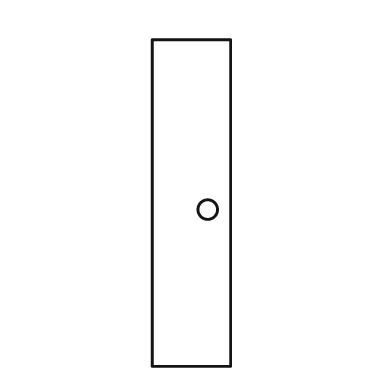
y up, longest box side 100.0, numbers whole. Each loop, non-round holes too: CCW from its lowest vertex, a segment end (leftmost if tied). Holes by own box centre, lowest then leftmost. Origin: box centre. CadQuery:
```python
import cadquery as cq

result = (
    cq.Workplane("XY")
    .moveTo(-12.0, -50.0)
    .lineTo(12.0, -50.0)
    .lineTo(12.0, 50.0)
    .lineTo(-12.0, 50.0)
    .close()
    .moveTo(5.0, -2.0)
    .circle(3.0)
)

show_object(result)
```